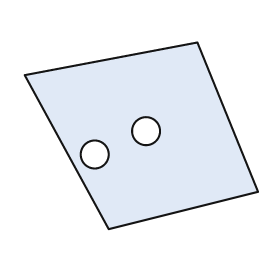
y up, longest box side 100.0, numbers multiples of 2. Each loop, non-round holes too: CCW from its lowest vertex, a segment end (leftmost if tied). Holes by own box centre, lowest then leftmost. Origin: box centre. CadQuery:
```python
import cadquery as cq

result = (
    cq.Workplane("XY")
    .moveTo(-14.0, -40.0)
    .lineTo(50.0, -24.0)
    .lineTo(24.0, 40.0)
    .lineTo(-50.0, 26.0)
    .close()
    .moveTo(-20.0, -8.0)
    .circle(6.0)
    .moveTo(2.0, 2.0)
    .circle(6.0)
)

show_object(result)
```